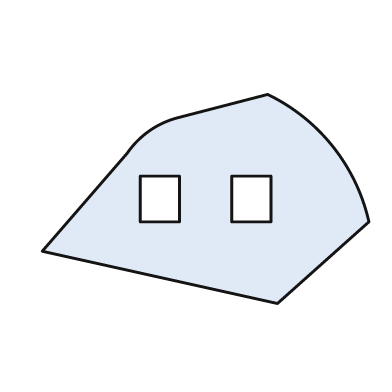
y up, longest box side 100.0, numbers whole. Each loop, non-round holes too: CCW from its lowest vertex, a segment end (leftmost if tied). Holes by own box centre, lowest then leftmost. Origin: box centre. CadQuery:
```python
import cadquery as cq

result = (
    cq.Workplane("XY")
    .moveTo(22.0, -32.0)
    .lineTo(50.0, -7.0)
    .threePointArc((39.0, 16.0), (19.0, 32.0))
    .lineTo(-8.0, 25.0)
    .threePointArc((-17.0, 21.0), (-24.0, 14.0))
    .lineTo(-50.0, -16.0)
    .close()
    .moveTo(-20.0, -7.0)
    .lineTo(-8.0, -7.0)
    .lineTo(-8.0, 7.0)
    .lineTo(-20.0, 7.0)
    .close()
    .moveTo(8.0, -7.0)
    .lineTo(20.0, -7.0)
    .lineTo(20.0, 7.0)
    .lineTo(8.0, 7.0)
    .close()
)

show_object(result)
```